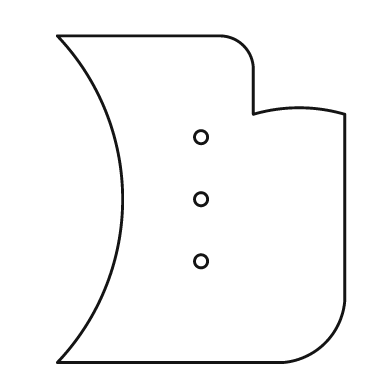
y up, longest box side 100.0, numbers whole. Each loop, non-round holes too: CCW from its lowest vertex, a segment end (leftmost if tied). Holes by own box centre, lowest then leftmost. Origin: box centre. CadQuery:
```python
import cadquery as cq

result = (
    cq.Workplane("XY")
    .moveTo(-44.0, -50.0)
    .lineTo(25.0, -50.0)
    .threePointArc((38.0, -44.0), (44.0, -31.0))
    .lineTo(44.0, 26.0)
    .threePointArc((30.0, 28.0), (16.0, 26.0))
    .lineTo(16.0, 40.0)
    .threePointArc((13.0, 47.0), (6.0, 50.0))
    .lineTo(-44.0, 50.0)
    .threePointArc((-24.0, 0.0), (-44.0, -50.0))
    .close()
    .moveTo(0.0, -19.0)
    .circle(2.0)
    .moveTo(0.0, 0.0)
    .circle(2.0)
    .moveTo(0.0, 19.0)
    .circle(2.0)
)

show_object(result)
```